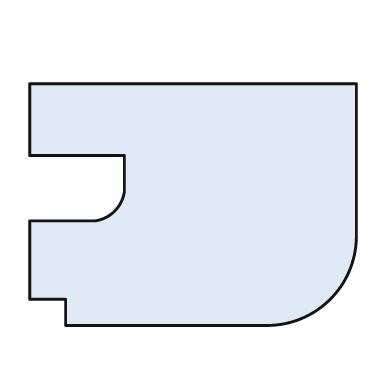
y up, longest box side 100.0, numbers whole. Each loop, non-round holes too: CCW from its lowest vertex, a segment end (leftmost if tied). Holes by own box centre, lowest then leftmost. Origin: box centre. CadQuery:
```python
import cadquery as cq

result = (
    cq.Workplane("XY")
    .moveTo(-39.0, -37.0)
    .lineTo(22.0, -37.0)
    .threePointArc((42.0, -29.0), (50.0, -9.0))
    .lineTo(50.0, 37.0)
    .lineTo(-50.0, 37.0)
    .lineTo(-50.0, 15.0)
    .lineTo(-21.0, 15.0)
    .lineTo(-21.0, 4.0)
    .threePointArc((-24.0, -2.0), (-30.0, -5.0))
    .lineTo(-50.0, -5.0)
    .lineTo(-50.0, -29.0)
    .lineTo(-39.0, -29.0)
    .close()
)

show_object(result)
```